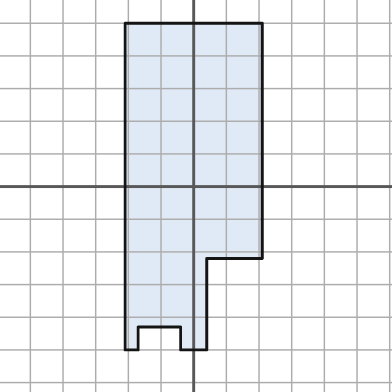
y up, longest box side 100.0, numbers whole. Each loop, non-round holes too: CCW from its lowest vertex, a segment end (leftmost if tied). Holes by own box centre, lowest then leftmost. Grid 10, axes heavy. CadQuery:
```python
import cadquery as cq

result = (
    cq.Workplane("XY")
    .moveTo(-21.0, -50.0)
    .lineTo(-17.0, -50.0)
    .lineTo(-17.0, -43.0)
    .lineTo(-4.0, -43.0)
    .lineTo(-4.0, -50.0)
    .lineTo(4.0, -50.0)
    .lineTo(4.0, -22.0)
    .lineTo(21.0, -22.0)
    .lineTo(21.0, 50.0)
    .lineTo(-21.0, 50.0)
    .close()
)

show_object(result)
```